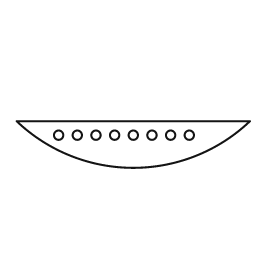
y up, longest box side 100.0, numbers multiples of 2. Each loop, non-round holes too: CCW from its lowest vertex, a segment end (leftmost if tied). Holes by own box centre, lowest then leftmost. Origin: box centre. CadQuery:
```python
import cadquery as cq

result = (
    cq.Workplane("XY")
    .moveTo(-50.0, 10.0)
    .threePointArc((0.0, -10.0), (50.0, 10.0))
    .close()
    .moveTo(-32.0, 4.0)
    .circle(2.0)
    .moveTo(-24.0, 4.0)
    .circle(2.0)
    .moveTo(-16.0, 4.0)
    .circle(2.0)
    .moveTo(-8.0, 4.0)
    .circle(2.0)
    .moveTo(0.0, 4.0)
    .circle(2.0)
    .moveTo(8.0, 4.0)
    .circle(2.0)
    .moveTo(16.0, 4.0)
    .circle(2.0)
    .moveTo(24.0, 4.0)
    .circle(2.0)
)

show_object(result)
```